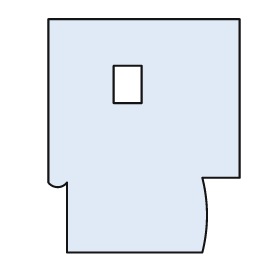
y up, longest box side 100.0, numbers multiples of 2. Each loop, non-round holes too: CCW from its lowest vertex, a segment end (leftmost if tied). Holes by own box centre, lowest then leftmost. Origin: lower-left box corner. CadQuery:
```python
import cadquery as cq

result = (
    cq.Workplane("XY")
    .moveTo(8.0, 0.0)
    .lineTo(66.0, 0.0)
    .threePointArc((68.0, 16.0), (66.0, 32.0))
    .lineTo(82.0, 32.0)
    .lineTo(82.0, 100.0)
    .lineTo(0.0, 100.0)
    .lineTo(0.0, 30.0)
    .threePointArc((4.0, 28.0), (8.0, 30.0))
    .close()
    .moveTo(28.0, 64.0)
    .lineTo(40.0, 64.0)
    .lineTo(40.0, 80.0)
    .lineTo(28.0, 80.0)
    .close()
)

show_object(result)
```